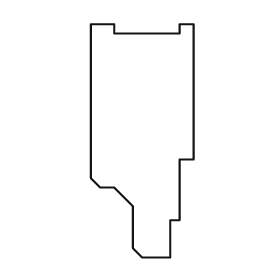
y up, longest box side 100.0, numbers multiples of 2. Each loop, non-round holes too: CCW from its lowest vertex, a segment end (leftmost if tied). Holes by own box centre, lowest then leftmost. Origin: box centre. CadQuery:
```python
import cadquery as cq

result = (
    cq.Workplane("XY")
    .moveTo(0.0, -50.0)
    .lineTo(12.0, -50.0)
    .lineTo(12.0, -34.0)
    .lineTo(16.0, -34.0)
    .lineTo(16.0, -8.0)
    .lineTo(22.0, -8.0)
    .lineTo(22.0, 50.0)
    .lineTo(16.0, 50.0)
    .lineTo(16.0, 46.0)
    .lineTo(-12.0, 46.0)
    .lineTo(-12.0, 50.0)
    .lineTo(-22.0, 50.0)
    .lineTo(-22.0, -16.0)
    .lineTo(-18.0, -20.0)
    .lineTo(-12.0, -20.0)
    .lineTo(-4.0, -28.0)
    .lineTo(-4.0, -46.0)
    .close()
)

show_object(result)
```